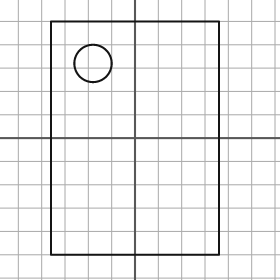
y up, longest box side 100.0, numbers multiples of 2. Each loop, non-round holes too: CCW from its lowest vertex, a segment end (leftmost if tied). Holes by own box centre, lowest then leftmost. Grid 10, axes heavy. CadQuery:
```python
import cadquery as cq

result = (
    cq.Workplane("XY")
    .moveTo(-36.0, -50.0)
    .lineTo(36.0, -50.0)
    .lineTo(36.0, 50.0)
    .lineTo(-36.0, 50.0)
    .close()
    .moveTo(-18.0, 32.0)
    .circle(8.0)
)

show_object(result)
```